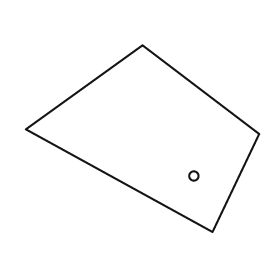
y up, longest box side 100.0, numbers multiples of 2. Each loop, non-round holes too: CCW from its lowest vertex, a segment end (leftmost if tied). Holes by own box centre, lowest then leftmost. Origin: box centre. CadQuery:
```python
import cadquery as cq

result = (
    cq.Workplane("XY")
    .moveTo(30.0, -40.0)
    .lineTo(50.0, 2.0)
    .lineTo(0.0, 40.0)
    .lineTo(-50.0, 4.0)
    .close()
    .moveTo(22.0, -16.0)
    .circle(2.0)
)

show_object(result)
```